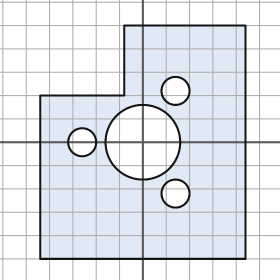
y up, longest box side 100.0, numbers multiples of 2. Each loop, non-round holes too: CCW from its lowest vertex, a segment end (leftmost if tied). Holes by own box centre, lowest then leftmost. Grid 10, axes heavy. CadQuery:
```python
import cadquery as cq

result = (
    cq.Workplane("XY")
    .moveTo(-44.0, -50.0)
    .lineTo(44.0, -50.0)
    .lineTo(44.0, 50.0)
    .lineTo(-8.0, 50.0)
    .lineTo(-8.0, 20.0)
    .lineTo(-44.0, 20.0)
    .close()
    .moveTo(14.0, -22.0)
    .circle(6.0)
    .moveTo(-26.0, 0.0)
    .circle(6.0)
    .moveTo(0.0, 0.0)
    .circle(16.0)
    .moveTo(14.0, 22.0)
    .circle(6.0)
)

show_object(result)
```